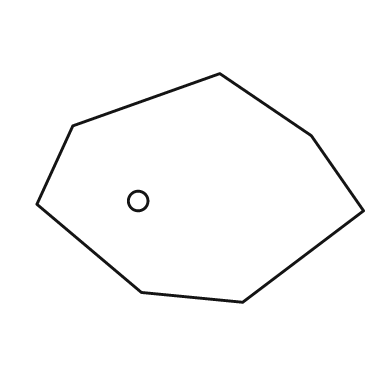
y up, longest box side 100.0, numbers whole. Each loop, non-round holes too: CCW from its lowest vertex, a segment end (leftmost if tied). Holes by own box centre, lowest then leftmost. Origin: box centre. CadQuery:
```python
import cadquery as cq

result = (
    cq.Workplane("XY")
    .moveTo(13.0, -35.0)
    .lineTo(50.0, -7.0)
    .lineTo(34.0, 16.0)
    .lineTo(6.0, 35.0)
    .lineTo(-39.0, 19.0)
    .lineTo(-50.0, -5.0)
    .lineTo(-18.0, -32.0)
    .close()
    .moveTo(-19.0, -4.0)
    .circle(3.0)
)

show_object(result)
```